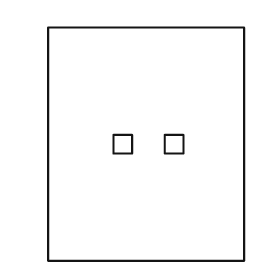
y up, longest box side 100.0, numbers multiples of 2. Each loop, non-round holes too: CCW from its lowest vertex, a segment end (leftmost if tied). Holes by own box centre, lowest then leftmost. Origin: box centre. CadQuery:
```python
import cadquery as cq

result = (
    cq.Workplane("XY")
    .moveTo(-42.0, -50.0)
    .lineTo(42.0, -50.0)
    .lineTo(42.0, 50.0)
    .lineTo(-42.0, 50.0)
    .close()
    .moveTo(-14.0, -4.0)
    .lineTo(-6.0, -4.0)
    .lineTo(-6.0, 4.0)
    .lineTo(-14.0, 4.0)
    .close()
    .moveTo(8.0, -4.0)
    .lineTo(16.0, -4.0)
    .lineTo(16.0, 4.0)
    .lineTo(8.0, 4.0)
    .close()
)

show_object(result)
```